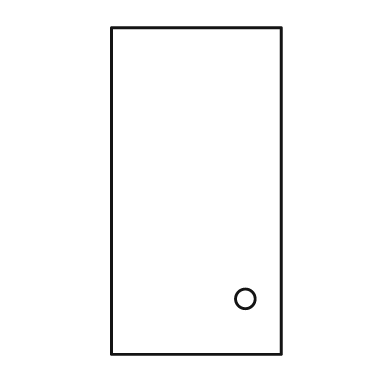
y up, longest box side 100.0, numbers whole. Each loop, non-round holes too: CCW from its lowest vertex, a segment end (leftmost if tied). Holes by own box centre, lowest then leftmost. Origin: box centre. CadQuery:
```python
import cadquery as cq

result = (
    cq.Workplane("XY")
    .moveTo(-26.0, -50.0)
    .lineTo(26.0, -50.0)
    .lineTo(26.0, 50.0)
    .lineTo(-26.0, 50.0)
    .close()
    .moveTo(15.0, -33.0)
    .circle(3.0)
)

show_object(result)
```